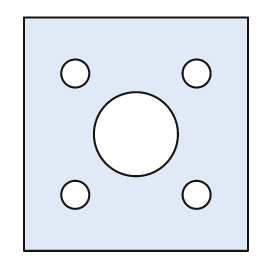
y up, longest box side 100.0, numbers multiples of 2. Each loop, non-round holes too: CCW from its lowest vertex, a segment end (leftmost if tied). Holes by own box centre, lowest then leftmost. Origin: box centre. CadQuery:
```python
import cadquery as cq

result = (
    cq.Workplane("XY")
    .moveTo(-48.0, -50.0)
    .lineTo(48.0, -50.0)
    .lineTo(48.0, 50.0)
    .lineTo(-48.0, 50.0)
    .close()
    .moveTo(-26.0, -26.0)
    .circle(6.0)
    .moveTo(26.0, -26.0)
    .circle(6.0)
    .moveTo(0.0, 0.0)
    .circle(18.0)
    .moveTo(-26.0, 26.0)
    .circle(6.0)
    .moveTo(26.0, 26.0)
    .circle(6.0)
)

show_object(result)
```